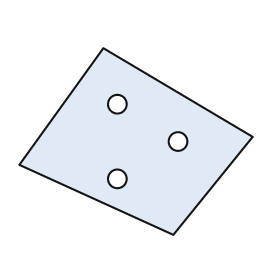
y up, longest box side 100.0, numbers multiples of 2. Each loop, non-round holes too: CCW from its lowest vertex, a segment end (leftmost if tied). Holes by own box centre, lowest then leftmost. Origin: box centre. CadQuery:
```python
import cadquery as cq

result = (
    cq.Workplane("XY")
    .moveTo(16.0, -40.0)
    .lineTo(50.0, 2.0)
    .lineTo(-14.0, 40.0)
    .lineTo(-50.0, -10.0)
    .close()
    .moveTo(-8.0, -16.0)
    .circle(4.0)
    .moveTo(18.0, 0.0)
    .circle(4.0)
    .moveTo(-8.0, 16.0)
    .circle(4.0)
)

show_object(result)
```